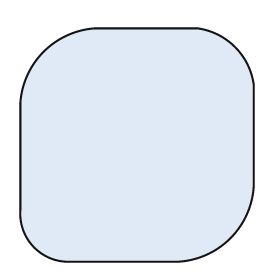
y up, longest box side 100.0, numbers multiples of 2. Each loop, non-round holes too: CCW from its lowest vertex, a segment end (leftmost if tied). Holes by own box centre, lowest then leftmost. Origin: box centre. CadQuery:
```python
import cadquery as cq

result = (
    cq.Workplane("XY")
    .moveTo(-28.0, -50.0)
    .lineTo(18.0, -50.0)
    .threePointArc((40.0, -40.0), (50.0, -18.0))
    .lineTo(50.0, 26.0)
    .threePointArc((42.0, 42.0), (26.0, 50.0))
    .lineTo(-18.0, 50.0)
    .threePointArc((-40.0, 40.0), (-50.0, 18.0))
    .lineTo(-50.0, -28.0)
    .threePointArc((-44.0, -44.0), (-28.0, -50.0))
    .close()
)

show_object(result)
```